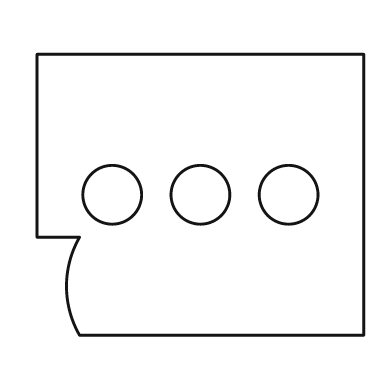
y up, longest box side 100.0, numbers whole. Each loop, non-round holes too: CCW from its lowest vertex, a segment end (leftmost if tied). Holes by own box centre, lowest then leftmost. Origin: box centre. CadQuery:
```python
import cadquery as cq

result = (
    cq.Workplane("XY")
    .moveTo(-37.0, -43.0)
    .lineTo(50.0, -43.0)
    .lineTo(50.0, 43.0)
    .lineTo(-50.0, 43.0)
    .lineTo(-50.0, -13.0)
    .lineTo(-37.0, -13.0)
    .threePointArc((-41.0, -28.0), (-37.0, -43.0))
    .close()
    .moveTo(-27.0, 0.0)
    .circle(9.0)
    .moveTo(0.0, 0.0)
    .circle(9.0)
    .moveTo(27.0, 0.0)
    .circle(9.0)
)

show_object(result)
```